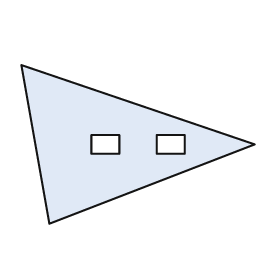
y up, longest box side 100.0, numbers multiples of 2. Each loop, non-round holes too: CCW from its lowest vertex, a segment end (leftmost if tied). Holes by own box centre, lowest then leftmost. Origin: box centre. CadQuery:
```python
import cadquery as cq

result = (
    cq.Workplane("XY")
    .moveTo(-38.0, -34.0)
    .lineTo(50.0, 0.0)
    .lineTo(-50.0, 34.0)
    .close()
    .moveTo(-20.0, -4.0)
    .lineTo(-8.0, -4.0)
    .lineTo(-8.0, 4.0)
    .lineTo(-20.0, 4.0)
    .close()
    .moveTo(8.0, -4.0)
    .lineTo(20.0, -4.0)
    .lineTo(20.0, 4.0)
    .lineTo(8.0, 4.0)
    .close()
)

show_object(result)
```